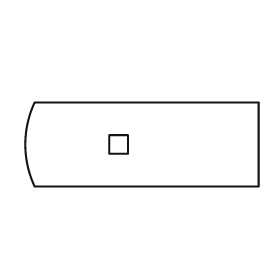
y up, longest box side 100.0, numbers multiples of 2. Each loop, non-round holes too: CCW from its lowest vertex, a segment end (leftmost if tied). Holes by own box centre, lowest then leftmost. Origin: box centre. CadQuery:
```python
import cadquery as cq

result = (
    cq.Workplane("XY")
    .moveTo(-46.0, -18.0)
    .lineTo(50.0, -18.0)
    .lineTo(50.0, 18.0)
    .lineTo(-46.0, 18.0)
    .threePointArc((-50.0, 0.0), (-46.0, -18.0))
    .close()
    .moveTo(-14.0, -4.0)
    .lineTo(-6.0, -4.0)
    .lineTo(-6.0, 4.0)
    .lineTo(-14.0, 4.0)
    .close()
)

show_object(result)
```